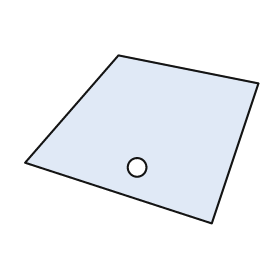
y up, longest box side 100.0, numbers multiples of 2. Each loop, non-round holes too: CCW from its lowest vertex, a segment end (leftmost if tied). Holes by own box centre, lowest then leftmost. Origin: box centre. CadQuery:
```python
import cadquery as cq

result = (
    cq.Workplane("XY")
    .moveTo(30.0, -36.0)
    .lineTo(50.0, 24.0)
    .lineTo(-10.0, 36.0)
    .lineTo(-50.0, -10.0)
    .close()
    .moveTo(-2.0, -12.0)
    .circle(4.0)
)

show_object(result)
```